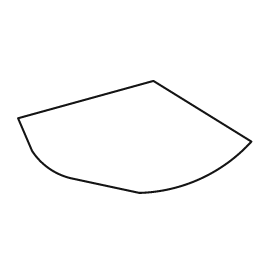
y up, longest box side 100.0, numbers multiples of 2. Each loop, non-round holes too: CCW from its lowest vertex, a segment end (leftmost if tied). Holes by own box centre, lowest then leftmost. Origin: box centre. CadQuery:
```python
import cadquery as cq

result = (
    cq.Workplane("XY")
    .moveTo(2.0, -24.0)
    .threePointArc((28.0, -18.0), (50.0, -2.0))
    .lineTo(8.0, 24.0)
    .lineTo(-50.0, 8.0)
    .lineTo(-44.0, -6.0)
    .threePointArc((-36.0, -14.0), (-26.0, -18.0))
    .close()
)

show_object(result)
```